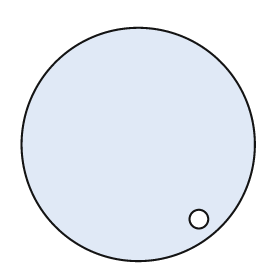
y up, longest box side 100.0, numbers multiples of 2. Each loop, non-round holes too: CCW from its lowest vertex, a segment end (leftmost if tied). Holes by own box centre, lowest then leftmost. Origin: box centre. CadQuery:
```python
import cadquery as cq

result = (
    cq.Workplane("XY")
    .moveTo(0.0, 0.0)
    .circle(50.0)
    .moveTo(26.0, -32.0)
    .circle(4.0)
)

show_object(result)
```